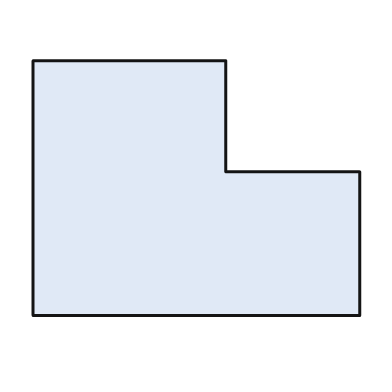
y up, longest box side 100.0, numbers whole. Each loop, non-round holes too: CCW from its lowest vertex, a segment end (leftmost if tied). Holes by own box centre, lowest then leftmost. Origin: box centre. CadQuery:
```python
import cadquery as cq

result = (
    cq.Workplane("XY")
    .moveTo(-50.0, -39.0)
    .lineTo(50.0, -39.0)
    .lineTo(50.0, 5.0)
    .lineTo(9.0, 5.0)
    .lineTo(9.0, 39.0)
    .lineTo(-50.0, 39.0)
    .close()
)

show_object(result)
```